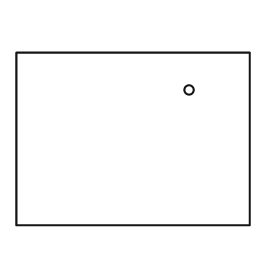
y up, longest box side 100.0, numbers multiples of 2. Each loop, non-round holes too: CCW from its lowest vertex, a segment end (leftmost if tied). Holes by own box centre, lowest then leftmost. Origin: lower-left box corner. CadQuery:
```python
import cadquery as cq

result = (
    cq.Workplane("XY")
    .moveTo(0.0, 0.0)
    .lineTo(100.0, 0.0)
    .lineTo(100.0, 74.0)
    .lineTo(0.0, 74.0)
    .close()
    .moveTo(74.0, 58.0)
    .circle(2.0)
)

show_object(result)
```